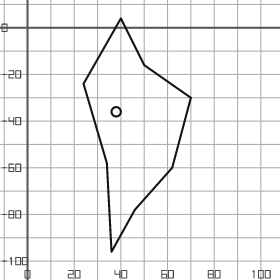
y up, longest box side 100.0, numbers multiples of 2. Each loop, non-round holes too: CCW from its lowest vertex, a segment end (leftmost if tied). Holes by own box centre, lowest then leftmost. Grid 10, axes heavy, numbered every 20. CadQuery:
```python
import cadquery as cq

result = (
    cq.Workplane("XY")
    .moveTo(36.0, -96.0)
    .lineTo(46.0, -78.0)
    .lineTo(62.0, -60.0)
    .lineTo(70.0, -30.0)
    .lineTo(50.0, -16.0)
    .lineTo(40.0, 4.0)
    .lineTo(24.0, -24.0)
    .lineTo(34.0, -58.0)
    .close()
    .moveTo(38.0, -36.0)
    .circle(2.0)
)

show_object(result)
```